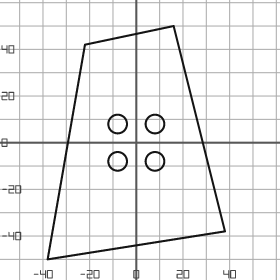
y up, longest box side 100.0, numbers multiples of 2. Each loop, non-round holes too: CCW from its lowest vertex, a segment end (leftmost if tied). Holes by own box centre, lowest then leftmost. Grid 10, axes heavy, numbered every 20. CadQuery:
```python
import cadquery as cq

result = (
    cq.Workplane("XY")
    .moveTo(-38.0, -50.0)
    .lineTo(38.0, -38.0)
    .lineTo(16.0, 50.0)
    .lineTo(-22.0, 42.0)
    .close()
    .moveTo(-8.0, -8.0)
    .circle(4.0)
    .moveTo(8.0, -8.0)
    .circle(4.0)
    .moveTo(-8.0, 8.0)
    .circle(4.0)
    .moveTo(8.0, 8.0)
    .circle(4.0)
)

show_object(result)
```